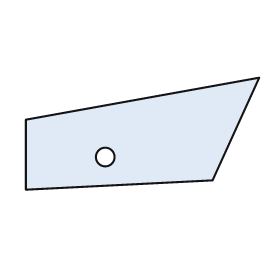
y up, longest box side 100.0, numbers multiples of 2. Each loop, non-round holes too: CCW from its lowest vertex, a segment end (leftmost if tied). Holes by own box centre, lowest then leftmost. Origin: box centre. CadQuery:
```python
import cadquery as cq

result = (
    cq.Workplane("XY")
    .moveTo(-50.0, -24.0)
    .lineTo(30.0, -20.0)
    .lineTo(50.0, 24.0)
    .lineTo(-50.0, 6.0)
    .close()
    .moveTo(-16.0, -10.0)
    .circle(4.0)
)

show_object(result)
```